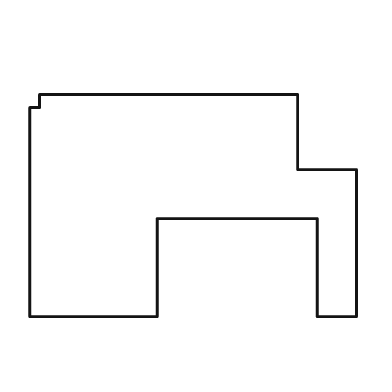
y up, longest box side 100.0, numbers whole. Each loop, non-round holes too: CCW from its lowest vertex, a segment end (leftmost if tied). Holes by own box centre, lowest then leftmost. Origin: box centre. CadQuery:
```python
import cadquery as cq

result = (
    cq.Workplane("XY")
    .moveTo(-50.0, -34.0)
    .lineTo(-11.0, -34.0)
    .lineTo(-11.0, -4.0)
    .lineTo(38.0, -4.0)
    .lineTo(38.0, -34.0)
    .lineTo(50.0, -34.0)
    .lineTo(50.0, 11.0)
    .lineTo(32.0, 11.0)
    .lineTo(32.0, 34.0)
    .lineTo(-47.0, 34.0)
    .lineTo(-47.0, 30.0)
    .lineTo(-50.0, 30.0)
    .close()
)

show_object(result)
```